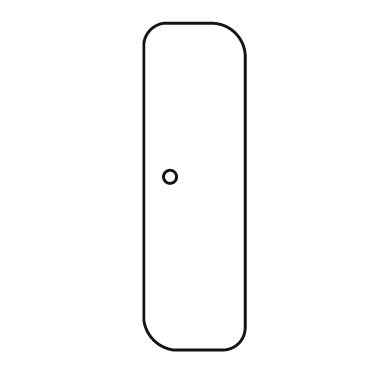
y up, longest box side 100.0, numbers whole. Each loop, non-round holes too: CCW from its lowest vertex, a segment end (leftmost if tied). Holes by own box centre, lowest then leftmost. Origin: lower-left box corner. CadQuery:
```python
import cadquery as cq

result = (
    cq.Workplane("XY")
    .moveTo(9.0, 0.0)
    .lineTo(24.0, 0.0)
    .threePointArc((29.0, 2.0), (31.0, 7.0))
    .lineTo(31.0, 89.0)
    .threePointArc((28.0, 97.0), (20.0, 100.0))
    .lineTo(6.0, 100.0)
    .threePointArc((2.0, 98.0), (0.0, 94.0))
    .lineTo(0.0, 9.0)
    .threePointArc((3.0, 3.0), (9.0, 0.0))
    .close()
    .moveTo(8.0, 53.0)
    .circle(2.0)
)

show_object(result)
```